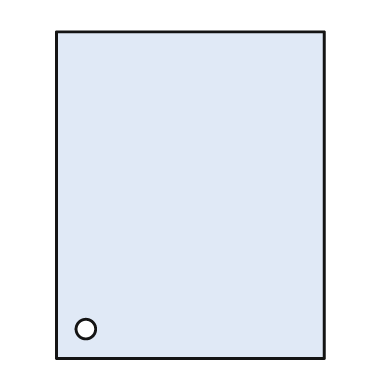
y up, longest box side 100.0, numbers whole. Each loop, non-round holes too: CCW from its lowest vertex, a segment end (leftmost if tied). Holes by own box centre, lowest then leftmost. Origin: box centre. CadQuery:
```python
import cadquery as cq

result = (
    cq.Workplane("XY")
    .moveTo(-41.0, -50.0)
    .lineTo(41.0, -50.0)
    .lineTo(41.0, 50.0)
    .lineTo(-41.0, 50.0)
    .close()
    .moveTo(-32.0, -41.0)
    .circle(3.0)
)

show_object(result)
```